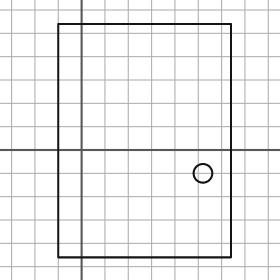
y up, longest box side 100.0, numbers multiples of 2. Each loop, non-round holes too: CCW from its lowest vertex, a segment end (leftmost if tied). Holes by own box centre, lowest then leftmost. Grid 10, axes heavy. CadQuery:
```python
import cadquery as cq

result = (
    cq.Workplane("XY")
    .moveTo(-10.0, -46.0)
    .lineTo(64.0, -46.0)
    .lineTo(64.0, 54.0)
    .lineTo(-10.0, 54.0)
    .close()
    .moveTo(52.0, -10.0)
    .circle(4.0)
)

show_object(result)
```